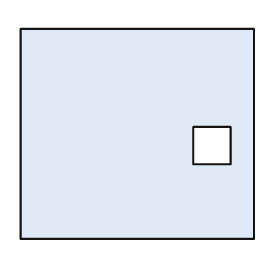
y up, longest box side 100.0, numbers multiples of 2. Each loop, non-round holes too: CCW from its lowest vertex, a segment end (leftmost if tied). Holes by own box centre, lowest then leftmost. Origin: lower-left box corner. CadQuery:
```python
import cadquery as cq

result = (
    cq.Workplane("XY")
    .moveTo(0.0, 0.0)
    .lineTo(100.0, 0.0)
    .lineTo(100.0, 90.0)
    .lineTo(0.0, 90.0)
    .close()
    .moveTo(74.0, 32.0)
    .lineTo(90.0, 32.0)
    .lineTo(90.0, 48.0)
    .lineTo(74.0, 48.0)
    .close()
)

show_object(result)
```